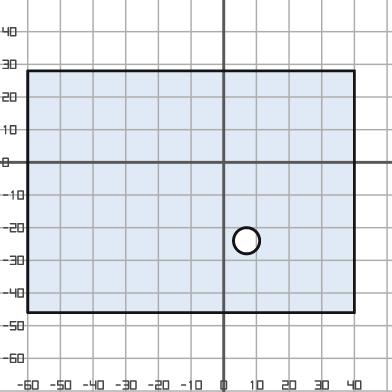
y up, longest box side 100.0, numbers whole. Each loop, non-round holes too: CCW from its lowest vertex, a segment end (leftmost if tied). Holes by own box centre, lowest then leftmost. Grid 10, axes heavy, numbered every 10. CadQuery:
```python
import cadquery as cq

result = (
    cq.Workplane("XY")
    .moveTo(-60.0, -46.0)
    .lineTo(40.0, -46.0)
    .lineTo(40.0, 28.0)
    .lineTo(-60.0, 28.0)
    .close()
    .moveTo(7.0, -24.0)
    .circle(4.0)
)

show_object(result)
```